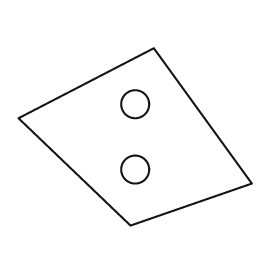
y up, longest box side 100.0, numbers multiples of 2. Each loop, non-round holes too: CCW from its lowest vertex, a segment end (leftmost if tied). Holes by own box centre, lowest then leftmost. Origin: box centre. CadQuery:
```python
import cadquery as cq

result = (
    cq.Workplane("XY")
    .moveTo(-2.0, -38.0)
    .lineTo(50.0, -20.0)
    .lineTo(8.0, 38.0)
    .lineTo(-50.0, 8.0)
    .close()
    .moveTo(0.0, -14.0)
    .circle(6.0)
    .moveTo(0.0, 14.0)
    .circle(6.0)
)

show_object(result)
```